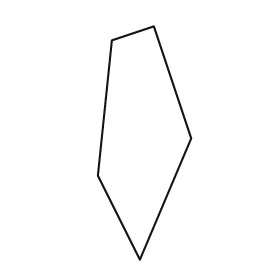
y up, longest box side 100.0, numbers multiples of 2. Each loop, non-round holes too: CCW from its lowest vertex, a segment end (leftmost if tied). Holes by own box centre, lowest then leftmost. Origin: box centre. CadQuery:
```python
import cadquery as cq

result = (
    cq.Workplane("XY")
    .moveTo(-2.0, -50.0)
    .lineTo(20.0, 2.0)
    .lineTo(4.0, 50.0)
    .lineTo(-14.0, 44.0)
    .lineTo(-20.0, -14.0)
    .close()
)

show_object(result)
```